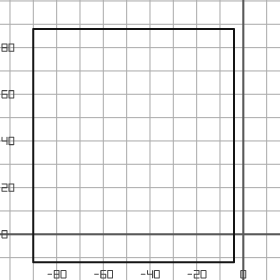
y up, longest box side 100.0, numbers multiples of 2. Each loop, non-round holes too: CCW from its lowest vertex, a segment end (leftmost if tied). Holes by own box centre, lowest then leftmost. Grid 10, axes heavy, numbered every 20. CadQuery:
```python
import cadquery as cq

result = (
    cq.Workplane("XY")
    .moveTo(-90.0, -12.0)
    .lineTo(-4.0, -12.0)
    .lineTo(-4.0, 88.0)
    .lineTo(-90.0, 88.0)
    .close()
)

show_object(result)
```